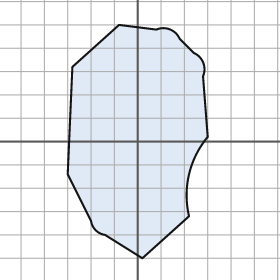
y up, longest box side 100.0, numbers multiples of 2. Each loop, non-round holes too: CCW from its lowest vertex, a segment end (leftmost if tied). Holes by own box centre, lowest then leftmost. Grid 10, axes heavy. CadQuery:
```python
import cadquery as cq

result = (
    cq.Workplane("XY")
    .moveTo(2.0, -50.0)
    .lineTo(22.0, -32.0)
    .threePointArc((22.0, -14.0), (30.0, 2.0))
    .lineTo(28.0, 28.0)
    .threePointArc((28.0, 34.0), (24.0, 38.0))
    .lineTo(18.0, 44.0)
    .threePointArc((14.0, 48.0), (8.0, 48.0))
    .lineTo(-8.0, 50.0)
    .lineTo(-28.0, 32.0)
    .lineTo(-30.0, -14.0)
    .lineTo(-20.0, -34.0)
    .threePointArc((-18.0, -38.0), (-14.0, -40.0))
    .close()
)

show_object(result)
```